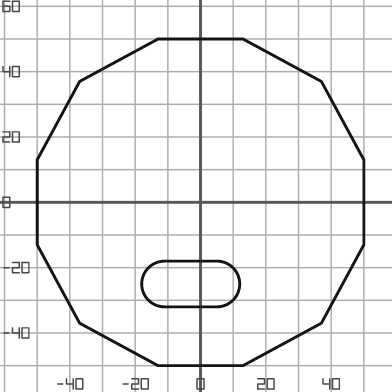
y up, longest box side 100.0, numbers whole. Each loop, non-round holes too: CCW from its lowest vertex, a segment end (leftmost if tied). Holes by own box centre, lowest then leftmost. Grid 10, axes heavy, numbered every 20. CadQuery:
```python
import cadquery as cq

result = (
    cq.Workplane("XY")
    .moveTo(-13.0, -50.0)
    .lineTo(13.0, -50.0)
    .lineTo(37.0, -37.0)
    .lineTo(50.0, -13.0)
    .lineTo(50.0, 13.0)
    .lineTo(37.0, 37.0)
    .lineTo(13.0, 50.0)
    .lineTo(-13.0, 50.0)
    .lineTo(-37.0, 37.0)
    .lineTo(-50.0, 13.0)
    .lineTo(-50.0, -13.0)
    .lineTo(-37.0, -37.0)
    .close()
    .moveTo(-11.0, -32.0)
    .lineTo(5.0, -32.0)
    .threePointArc((12.0, -25.0), (5.0, -18.0))
    .lineTo(-11.0, -18.0)
    .threePointArc((-18.0, -25.0), (-11.0, -32.0))
    .close()
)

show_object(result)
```